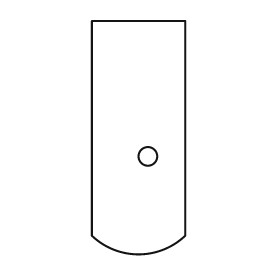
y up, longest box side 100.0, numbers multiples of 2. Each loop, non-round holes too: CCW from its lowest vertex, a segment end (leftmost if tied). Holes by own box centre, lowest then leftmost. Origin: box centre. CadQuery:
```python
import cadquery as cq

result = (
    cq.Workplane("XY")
    .moveTo(-20.0, -42.0)
    .threePointArc((0.0, -50.0), (20.0, -42.0))
    .lineTo(20.0, 50.0)
    .lineTo(-20.0, 50.0)
    .close()
    .moveTo(4.0, -8.0)
    .circle(4.0)
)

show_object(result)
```